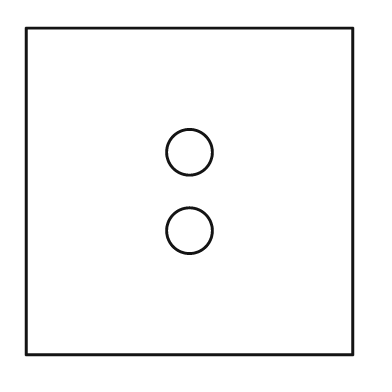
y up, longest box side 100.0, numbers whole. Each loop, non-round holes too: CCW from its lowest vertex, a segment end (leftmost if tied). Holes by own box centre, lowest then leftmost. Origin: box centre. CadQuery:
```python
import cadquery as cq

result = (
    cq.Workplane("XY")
    .moveTo(-50.0, -50.0)
    .lineTo(50.0, -50.0)
    .lineTo(50.0, 50.0)
    .lineTo(-50.0, 50.0)
    .close()
    .moveTo(0.0, -12.0)
    .circle(7.0)
    .moveTo(0.0, 12.0)
    .circle(7.0)
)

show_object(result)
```